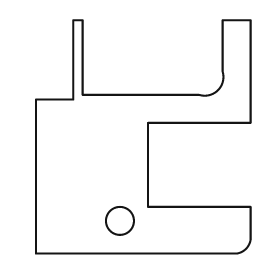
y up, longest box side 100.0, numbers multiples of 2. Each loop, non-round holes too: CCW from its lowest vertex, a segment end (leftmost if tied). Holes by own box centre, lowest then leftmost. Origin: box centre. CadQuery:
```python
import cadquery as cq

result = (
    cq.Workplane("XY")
    .moveTo(-46.0, -50.0)
    .lineTo(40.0, -50.0)
    .threePointArc((44.0, -48.0), (46.0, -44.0))
    .lineTo(46.0, -30.0)
    .lineTo(2.0, -30.0)
    .lineTo(2.0, 6.0)
    .lineTo(46.0, 6.0)
    .lineTo(46.0, 50.0)
    .lineTo(34.0, 50.0)
    .lineTo(34.0, 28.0)
    .threePointArc((32.0, 20.0), (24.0, 18.0))
    .lineTo(-26.0, 18.0)
    .lineTo(-26.0, 50.0)
    .lineTo(-30.0, 50.0)
    .lineTo(-30.0, 16.0)
    .lineTo(-46.0, 16.0)
    .close()
    .moveTo(-10.0, -36.0)
    .circle(6.0)
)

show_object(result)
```